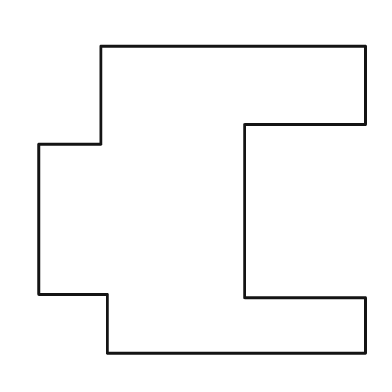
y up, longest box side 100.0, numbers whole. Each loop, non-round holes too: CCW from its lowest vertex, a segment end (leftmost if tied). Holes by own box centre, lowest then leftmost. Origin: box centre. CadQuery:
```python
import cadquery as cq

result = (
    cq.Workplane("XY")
    .moveTo(-29.0, -47.0)
    .lineTo(50.0, -47.0)
    .lineTo(50.0, -30.0)
    .lineTo(13.0, -30.0)
    .lineTo(13.0, 23.0)
    .lineTo(50.0, 23.0)
    .lineTo(50.0, 47.0)
    .lineTo(-31.0, 47.0)
    .lineTo(-31.0, 17.0)
    .lineTo(-50.0, 17.0)
    .lineTo(-50.0, -29.0)
    .lineTo(-29.0, -29.0)
    .close()
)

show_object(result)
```